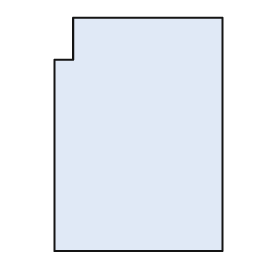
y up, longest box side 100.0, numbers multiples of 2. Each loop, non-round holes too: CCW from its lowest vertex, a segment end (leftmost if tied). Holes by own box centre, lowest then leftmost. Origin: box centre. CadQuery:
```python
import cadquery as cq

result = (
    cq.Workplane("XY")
    .moveTo(-36.0, -50.0)
    .lineTo(36.0, -50.0)
    .lineTo(36.0, 50.0)
    .lineTo(-28.0, 50.0)
    .lineTo(-28.0, 32.0)
    .lineTo(-36.0, 32.0)
    .close()
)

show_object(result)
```